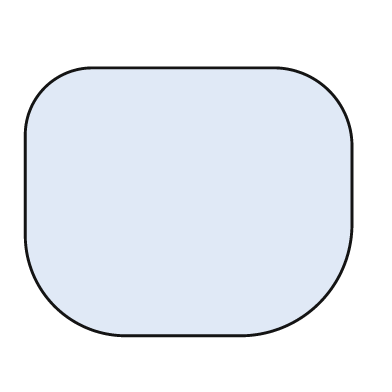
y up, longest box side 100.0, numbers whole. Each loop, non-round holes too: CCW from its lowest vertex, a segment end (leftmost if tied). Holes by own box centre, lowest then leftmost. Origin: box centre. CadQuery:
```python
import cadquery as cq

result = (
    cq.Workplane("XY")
    .moveTo(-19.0, -41.0)
    .lineTo(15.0, -41.0)
    .threePointArc((40.0, -31.0), (50.0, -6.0))
    .lineTo(50.0, 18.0)
    .threePointArc((43.0, 34.0), (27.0, 41.0))
    .lineTo(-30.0, 41.0)
    .threePointArc((-44.0, 35.0), (-50.0, 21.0))
    .lineTo(-50.0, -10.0)
    .threePointArc((-41.0, -32.0), (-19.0, -41.0))
    .close()
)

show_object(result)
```